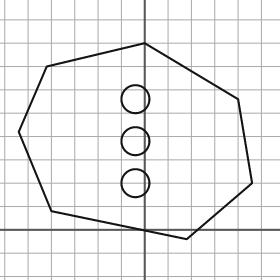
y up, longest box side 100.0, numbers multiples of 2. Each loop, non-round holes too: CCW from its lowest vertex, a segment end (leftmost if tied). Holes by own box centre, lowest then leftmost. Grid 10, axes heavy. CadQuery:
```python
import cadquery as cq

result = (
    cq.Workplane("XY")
    .moveTo(18.0, -4.0)
    .lineTo(46.0, 20.0)
    .lineTo(40.0, 56.0)
    .lineTo(0.0, 80.0)
    .lineTo(-42.0, 70.0)
    .lineTo(-54.0, 42.0)
    .lineTo(-40.0, 8.0)
    .close()
    .moveTo(-4.0, 20.0)
    .circle(6.0)
    .moveTo(-4.0, 38.0)
    .circle(6.0)
    .moveTo(-4.0, 56.0)
    .circle(6.0)
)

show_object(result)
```